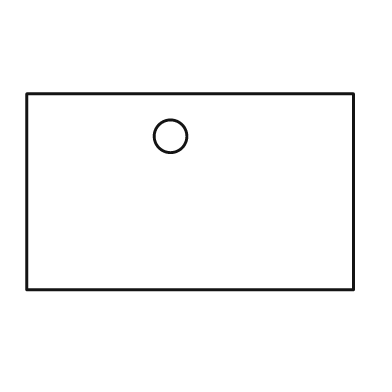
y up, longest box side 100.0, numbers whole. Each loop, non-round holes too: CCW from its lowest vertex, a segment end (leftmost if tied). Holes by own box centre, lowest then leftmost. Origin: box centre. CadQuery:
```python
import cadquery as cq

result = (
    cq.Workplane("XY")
    .moveTo(-50.0, -30.0)
    .lineTo(50.0, -30.0)
    .lineTo(50.0, 30.0)
    .lineTo(-50.0, 30.0)
    .close()
    .moveTo(-6.0, 17.0)
    .circle(5.0)
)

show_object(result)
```